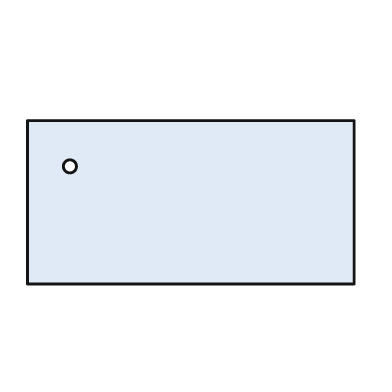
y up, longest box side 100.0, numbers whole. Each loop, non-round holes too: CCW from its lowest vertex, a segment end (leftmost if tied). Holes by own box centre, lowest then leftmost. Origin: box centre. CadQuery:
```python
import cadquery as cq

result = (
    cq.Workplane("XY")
    .moveTo(-50.0, -25.0)
    .lineTo(50.0, -25.0)
    .lineTo(50.0, 25.0)
    .lineTo(-50.0, 25.0)
    .close()
    .moveTo(-37.0, 11.0)
    .circle(2.0)
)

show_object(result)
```